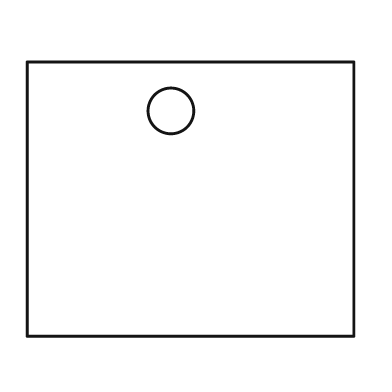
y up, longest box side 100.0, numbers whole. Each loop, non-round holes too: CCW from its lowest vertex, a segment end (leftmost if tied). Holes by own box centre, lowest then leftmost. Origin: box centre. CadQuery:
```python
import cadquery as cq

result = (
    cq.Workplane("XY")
    .moveTo(-50.0, -42.0)
    .lineTo(50.0, -42.0)
    .lineTo(50.0, 42.0)
    .lineTo(-50.0, 42.0)
    .close()
    .moveTo(-6.0, 27.0)
    .circle(7.0)
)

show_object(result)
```